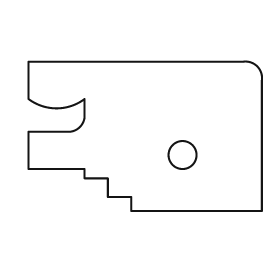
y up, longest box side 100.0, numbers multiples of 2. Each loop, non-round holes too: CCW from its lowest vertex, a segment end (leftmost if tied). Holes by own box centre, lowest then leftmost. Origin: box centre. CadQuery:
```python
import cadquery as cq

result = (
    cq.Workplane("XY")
    .moveTo(-6.0, -32.0)
    .lineTo(50.0, -32.0)
    .lineTo(50.0, 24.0)
    .threePointArc((48.0, 30.0), (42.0, 32.0))
    .lineTo(-50.0, 32.0)
    .lineTo(-50.0, 16.0)
    .threePointArc((-38.0, 12.0), (-26.0, 16.0))
    .lineTo(-26.0, 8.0)
    .threePointArc((-28.0, 4.0), (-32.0, 2.0))
    .lineTo(-50.0, 2.0)
    .lineTo(-50.0, -14.0)
    .lineTo(-26.0, -14.0)
    .lineTo(-26.0, -18.0)
    .lineTo(-16.0, -18.0)
    .lineTo(-16.0, -26.0)
    .lineTo(-6.0, -26.0)
    .close()
    .moveTo(16.0, -8.0)
    .circle(6.0)
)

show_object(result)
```